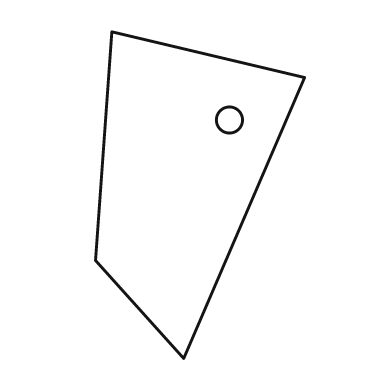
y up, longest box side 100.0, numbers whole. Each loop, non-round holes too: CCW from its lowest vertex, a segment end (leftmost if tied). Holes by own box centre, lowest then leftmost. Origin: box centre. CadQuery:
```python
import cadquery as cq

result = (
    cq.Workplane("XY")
    .moveTo(-5.0, -50.0)
    .lineTo(32.0, 36.0)
    .lineTo(-27.0, 50.0)
    .lineTo(-32.0, -20.0)
    .close()
    .moveTo(9.0, 23.0)
    .circle(4.0)
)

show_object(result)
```